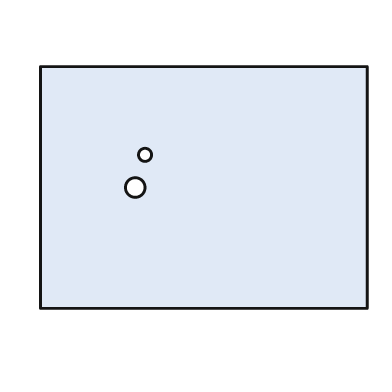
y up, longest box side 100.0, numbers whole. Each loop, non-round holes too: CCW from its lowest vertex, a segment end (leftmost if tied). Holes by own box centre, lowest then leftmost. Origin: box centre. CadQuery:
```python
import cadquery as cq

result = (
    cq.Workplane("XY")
    .moveTo(-50.0, -37.0)
    .lineTo(50.0, -37.0)
    .lineTo(50.0, 37.0)
    .lineTo(-50.0, 37.0)
    .close()
    .moveTo(-21.0, 0.0)
    .circle(3.0)
    .moveTo(-18.0, 10.0)
    .circle(2.0)
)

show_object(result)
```